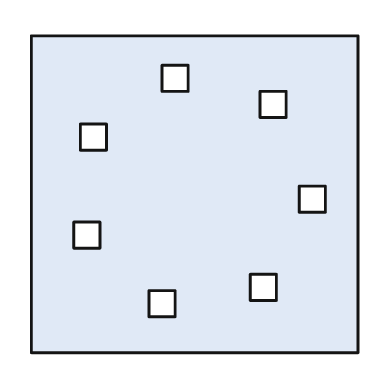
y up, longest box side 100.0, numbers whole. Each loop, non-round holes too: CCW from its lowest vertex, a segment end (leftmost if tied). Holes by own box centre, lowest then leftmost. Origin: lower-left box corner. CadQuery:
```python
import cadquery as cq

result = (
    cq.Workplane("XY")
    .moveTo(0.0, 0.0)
    .lineTo(100.0, 0.0)
    .lineTo(100.0, 97.0)
    .lineTo(0.0, 97.0)
    .close()
    .moveTo(36.0, 11.0)
    .lineTo(44.0, 11.0)
    .lineTo(44.0, 19.0)
    .lineTo(36.0, 19.0)
    .close()
    .moveTo(67.0, 16.0)
    .lineTo(75.0, 16.0)
    .lineTo(75.0, 24.0)
    .lineTo(67.0, 24.0)
    .close()
    .moveTo(13.0, 32.0)
    .lineTo(21.0, 32.0)
    .lineTo(21.0, 40.0)
    .lineTo(13.0, 40.0)
    .close()
    .moveTo(82.0, 43.0)
    .lineTo(90.0, 43.0)
    .lineTo(90.0, 51.0)
    .lineTo(82.0, 51.0)
    .close()
    .moveTo(15.0, 62.0)
    .lineTo(23.0, 62.0)
    .lineTo(23.0, 70.0)
    .lineTo(15.0, 70.0)
    .close()
    .moveTo(70.0, 72.0)
    .lineTo(78.0, 72.0)
    .lineTo(78.0, 80.0)
    .lineTo(70.0, 80.0)
    .close()
    .moveTo(40.0, 80.0)
    .lineTo(48.0, 80.0)
    .lineTo(48.0, 88.0)
    .lineTo(40.0, 88.0)
    .close()
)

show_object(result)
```